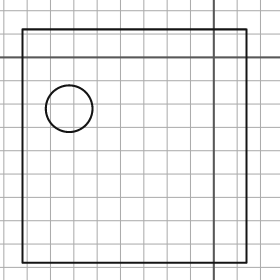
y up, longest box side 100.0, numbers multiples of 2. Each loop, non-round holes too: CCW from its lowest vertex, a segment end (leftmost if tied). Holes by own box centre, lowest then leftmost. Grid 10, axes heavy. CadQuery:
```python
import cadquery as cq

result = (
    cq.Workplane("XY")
    .moveTo(-82.0, -88.0)
    .lineTo(14.0, -88.0)
    .lineTo(14.0, 12.0)
    .lineTo(-82.0, 12.0)
    .close()
    .moveTo(-62.0, -22.0)
    .circle(10.0)
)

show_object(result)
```